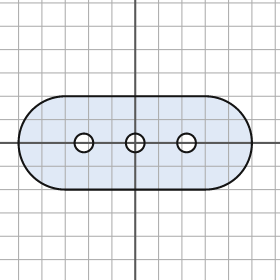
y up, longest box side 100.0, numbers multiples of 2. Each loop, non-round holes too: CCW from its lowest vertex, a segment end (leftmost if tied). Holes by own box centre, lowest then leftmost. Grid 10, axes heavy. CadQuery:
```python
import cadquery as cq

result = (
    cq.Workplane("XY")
    .moveTo(-30.0, -20.0)
    .lineTo(30.0, -20.0)
    .threePointArc((50.0, 0.0), (30.0, 20.0))
    .lineTo(-30.0, 20.0)
    .threePointArc((-50.0, 0.0), (-30.0, -20.0))
    .close()
    .moveTo(-22.0, 0.0)
    .circle(4.0)
    .moveTo(0.0, 0.0)
    .circle(4.0)
    .moveTo(22.0, 0.0)
    .circle(4.0)
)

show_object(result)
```